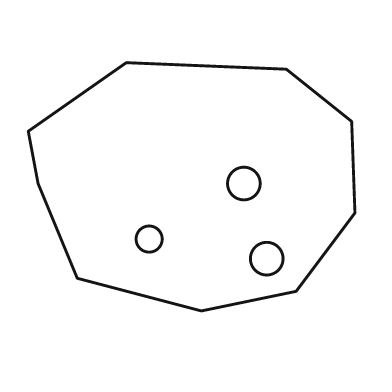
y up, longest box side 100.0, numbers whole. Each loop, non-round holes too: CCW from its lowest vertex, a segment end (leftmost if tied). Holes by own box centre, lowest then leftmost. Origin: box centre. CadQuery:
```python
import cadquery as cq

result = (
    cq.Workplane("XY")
    .moveTo(3.0, -38.0)
    .lineTo(32.0, -32.0)
    .lineTo(50.0, -8.0)
    .lineTo(49.0, 20.0)
    .lineTo(29.0, 36.0)
    .lineTo(-20.0, 38.0)
    .lineTo(-50.0, 17.0)
    .lineTo(-47.0, 1.0)
    .lineTo(-35.0, -28.0)
    .close()
    .moveTo(23.0, -22.0)
    .circle(5.0)
    .moveTo(-13.0, -16.0)
    .circle(4.0)
    .moveTo(16.0, 1.0)
    .circle(5.0)
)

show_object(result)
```